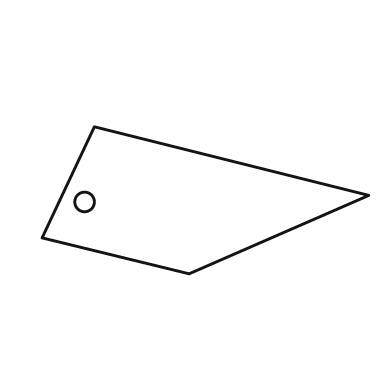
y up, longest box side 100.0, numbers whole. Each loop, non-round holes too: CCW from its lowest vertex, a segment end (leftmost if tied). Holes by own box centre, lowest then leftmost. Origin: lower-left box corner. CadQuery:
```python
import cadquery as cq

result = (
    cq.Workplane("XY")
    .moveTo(45.0, 0.0)
    .lineTo(100.0, 24.0)
    .lineTo(16.0, 45.0)
    .lineTo(0.0, 11.0)
    .close()
    .moveTo(13.0, 22.0)
    .circle(3.0)
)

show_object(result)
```